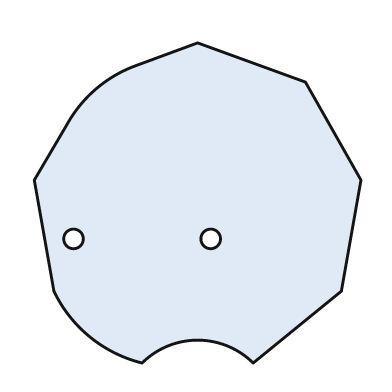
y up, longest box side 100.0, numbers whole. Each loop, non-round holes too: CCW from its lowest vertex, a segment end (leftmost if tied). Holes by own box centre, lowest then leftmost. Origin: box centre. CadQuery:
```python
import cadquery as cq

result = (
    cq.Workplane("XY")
    .moveTo(-17.0, -49.0)
    .threePointArc((0.0, -42.0), (17.0, -49.0))
    .lineTo(44.0, -27.0)
    .lineTo(50.0, 7.0)
    .lineTo(33.0, 37.0)
    .lineTo(0.0, 49.0)
    .lineTo(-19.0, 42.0)
    .threePointArc((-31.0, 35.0), (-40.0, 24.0))
    .lineTo(-50.0, 7.0)
    .lineTo(-44.0, -27.0)
    .threePointArc((-33.0, -41.0), (-17.0, -49.0))
    .close()
    .moveTo(-38.0, -11.0)
    .circle(3.0)
    .moveTo(4.0, -11.0)
    .circle(3.0)
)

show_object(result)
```